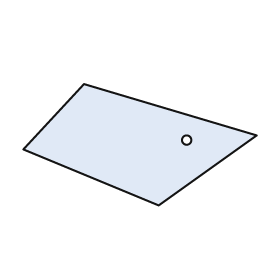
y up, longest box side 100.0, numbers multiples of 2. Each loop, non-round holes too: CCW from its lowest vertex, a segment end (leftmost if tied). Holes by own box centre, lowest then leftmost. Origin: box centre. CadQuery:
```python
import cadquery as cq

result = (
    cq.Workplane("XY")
    .moveTo(8.0, -26.0)
    .lineTo(50.0, 4.0)
    .lineTo(-24.0, 26.0)
    .lineTo(-50.0, -2.0)
    .close()
    .moveTo(20.0, 2.0)
    .circle(2.0)
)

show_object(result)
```